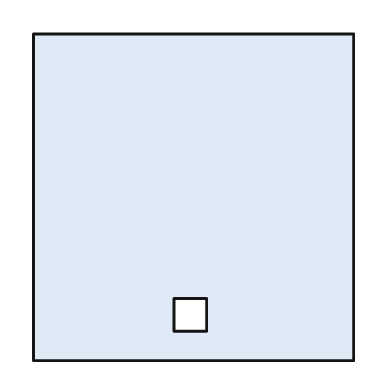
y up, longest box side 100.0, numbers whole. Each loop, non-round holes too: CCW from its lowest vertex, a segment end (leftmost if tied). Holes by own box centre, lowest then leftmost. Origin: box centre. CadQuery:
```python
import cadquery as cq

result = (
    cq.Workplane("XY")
    .moveTo(-49.0, -50.0)
    .lineTo(49.0, -50.0)
    .lineTo(49.0, 50.0)
    .lineTo(-49.0, 50.0)
    .close()
    .moveTo(-6.0, -41.0)
    .lineTo(4.0, -41.0)
    .lineTo(4.0, -31.0)
    .lineTo(-6.0, -31.0)
    .close()
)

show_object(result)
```